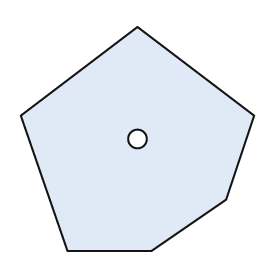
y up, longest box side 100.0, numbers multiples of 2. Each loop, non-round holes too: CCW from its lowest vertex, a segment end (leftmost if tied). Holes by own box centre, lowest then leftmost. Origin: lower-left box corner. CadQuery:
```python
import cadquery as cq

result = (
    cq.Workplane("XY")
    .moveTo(20.0, 0.0)
    .lineTo(56.0, 0.0)
    .lineTo(88.0, 22.0)
    .lineTo(100.0, 58.0)
    .lineTo(50.0, 96.0)
    .lineTo(0.0, 58.0)
    .close()
    .moveTo(50.0, 48.0)
    .circle(4.0)
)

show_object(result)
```